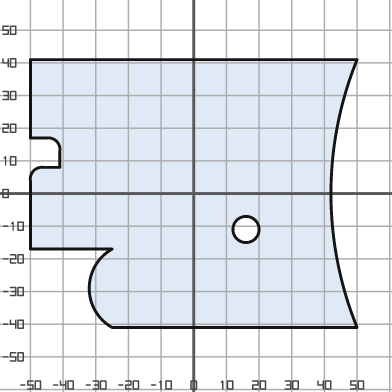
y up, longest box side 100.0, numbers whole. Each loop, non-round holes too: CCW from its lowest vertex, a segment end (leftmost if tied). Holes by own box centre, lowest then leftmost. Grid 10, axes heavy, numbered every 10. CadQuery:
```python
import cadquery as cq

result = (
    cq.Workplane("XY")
    .moveTo(-25.0, -41.0)
    .lineTo(50.0, -41.0)
    .threePointArc((42.0, 0.0), (50.0, 41.0))
    .lineTo(-50.0, 41.0)
    .lineTo(-50.0, 17.0)
    .lineTo(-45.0, 17.0)
    .threePointArc((-42.0, 16.0), (-41.0, 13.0))
    .lineTo(-41.0, 8.0)
    .lineTo(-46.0, 8.0)
    .threePointArc((-49.0, 7.0), (-50.0, 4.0))
    .lineTo(-50.0, -17.0)
    .lineTo(-25.0, -17.0)
    .threePointArc((-32.0, -29.0), (-25.0, -41.0))
    .close()
    .moveTo(16.0, -11.0)
    .circle(4.0)
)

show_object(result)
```